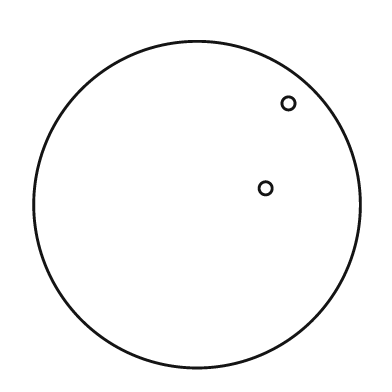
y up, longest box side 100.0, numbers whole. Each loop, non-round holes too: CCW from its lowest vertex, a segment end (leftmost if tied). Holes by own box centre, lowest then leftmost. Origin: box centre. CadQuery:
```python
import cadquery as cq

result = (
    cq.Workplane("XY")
    .moveTo(0.0, 0.0)
    .circle(50.0)
    .moveTo(21.0, 5.0)
    .circle(2.0)
    .moveTo(28.0, 31.0)
    .circle(2.0)
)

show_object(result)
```